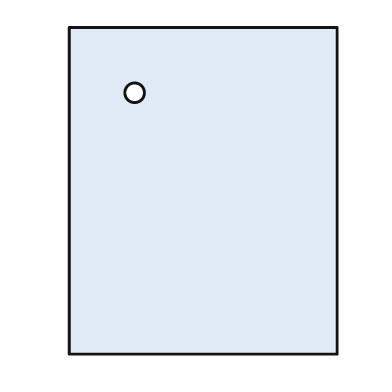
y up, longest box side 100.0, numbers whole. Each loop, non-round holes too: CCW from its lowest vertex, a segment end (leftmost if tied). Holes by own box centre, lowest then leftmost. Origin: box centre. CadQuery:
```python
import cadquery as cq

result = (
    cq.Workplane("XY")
    .moveTo(-41.0, -50.0)
    .lineTo(41.0, -50.0)
    .lineTo(41.0, 50.0)
    .lineTo(-41.0, 50.0)
    .close()
    .moveTo(-21.0, 30.0)
    .circle(3.0)
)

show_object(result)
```